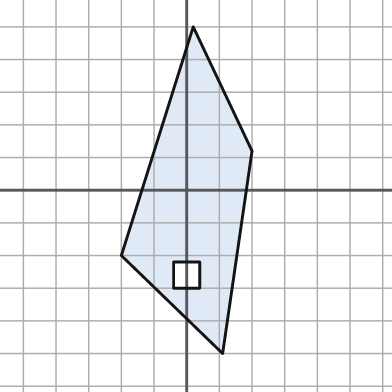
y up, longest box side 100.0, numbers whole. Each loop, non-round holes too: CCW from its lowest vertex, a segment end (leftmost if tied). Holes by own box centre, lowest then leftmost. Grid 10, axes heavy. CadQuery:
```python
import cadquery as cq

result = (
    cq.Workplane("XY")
    .moveTo(11.0, -50.0)
    .lineTo(20.0, 12.0)
    .lineTo(2.0, 50.0)
    .lineTo(-20.0, -20.0)
    .close()
    .moveTo(-4.0, -30.0)
    .lineTo(4.0, -30.0)
    .lineTo(4.0, -22.0)
    .lineTo(-4.0, -22.0)
    .close()
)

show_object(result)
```